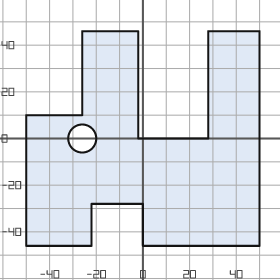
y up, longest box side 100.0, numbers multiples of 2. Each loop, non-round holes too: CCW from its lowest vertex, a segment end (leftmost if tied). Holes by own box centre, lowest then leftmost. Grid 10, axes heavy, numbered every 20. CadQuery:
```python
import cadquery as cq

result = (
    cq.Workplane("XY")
    .moveTo(-50.0, -46.0)
    .lineTo(-22.0, -46.0)
    .lineTo(-22.0, -28.0)
    .lineTo(0.0, -28.0)
    .lineTo(0.0, -46.0)
    .lineTo(50.0, -46.0)
    .lineTo(50.0, 46.0)
    .lineTo(28.0, 46.0)
    .lineTo(28.0, 0.0)
    .lineTo(-2.0, 0.0)
    .lineTo(-2.0, 46.0)
    .lineTo(-26.0, 46.0)
    .lineTo(-26.0, 10.0)
    .lineTo(-50.0, 10.0)
    .close()
    .moveTo(-26.0, 0.0)
    .circle(6.0)
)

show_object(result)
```